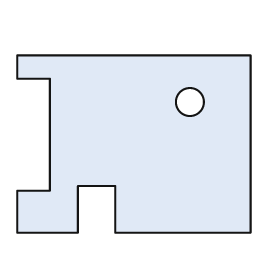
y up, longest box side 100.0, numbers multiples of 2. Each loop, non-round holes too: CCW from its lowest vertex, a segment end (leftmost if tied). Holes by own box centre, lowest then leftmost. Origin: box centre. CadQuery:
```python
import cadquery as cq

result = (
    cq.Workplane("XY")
    .moveTo(-50.0, -38.0)
    .lineTo(-24.0, -38.0)
    .lineTo(-24.0, -18.0)
    .lineTo(-8.0, -18.0)
    .lineTo(-8.0, -38.0)
    .lineTo(50.0, -38.0)
    .lineTo(50.0, 38.0)
    .lineTo(-50.0, 38.0)
    .lineTo(-50.0, 28.0)
    .lineTo(-36.0, 28.0)
    .lineTo(-36.0, -20.0)
    .lineTo(-50.0, -20.0)
    .close()
    .moveTo(24.0, 18.0)
    .circle(6.0)
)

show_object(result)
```